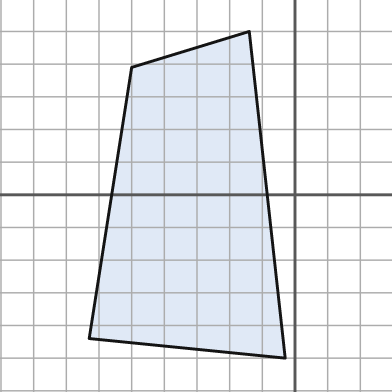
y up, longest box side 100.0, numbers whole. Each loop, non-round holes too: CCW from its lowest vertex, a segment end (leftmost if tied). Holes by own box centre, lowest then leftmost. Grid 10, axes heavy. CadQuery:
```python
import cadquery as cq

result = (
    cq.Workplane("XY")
    .moveTo(-3.0, -50.0)
    .lineTo(-14.0, 50.0)
    .lineTo(-50.0, 39.0)
    .lineTo(-63.0, -44.0)
    .close()
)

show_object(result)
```